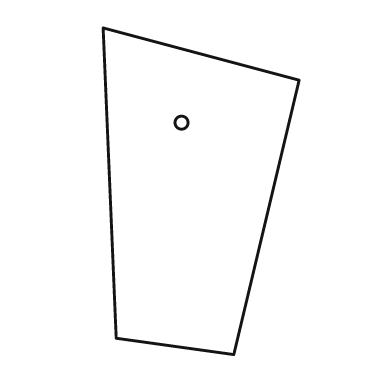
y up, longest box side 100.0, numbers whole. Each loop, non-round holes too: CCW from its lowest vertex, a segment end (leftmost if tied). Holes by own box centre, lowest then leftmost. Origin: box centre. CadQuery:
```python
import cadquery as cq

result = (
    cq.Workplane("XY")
    .moveTo(10.0, -50.0)
    .lineTo(30.0, 34.0)
    .lineTo(-30.0, 50.0)
    .lineTo(-26.0, -45.0)
    .close()
    .moveTo(-6.0, 21.0)
    .circle(2.0)
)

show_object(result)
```